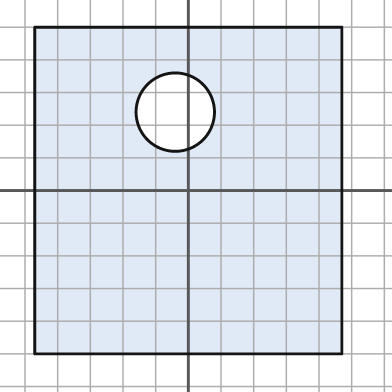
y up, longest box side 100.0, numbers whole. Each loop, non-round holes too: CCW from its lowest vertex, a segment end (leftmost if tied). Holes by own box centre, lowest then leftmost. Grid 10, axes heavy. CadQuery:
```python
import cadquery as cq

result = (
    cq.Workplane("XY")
    .moveTo(-47.0, -50.0)
    .lineTo(47.0, -50.0)
    .lineTo(47.0, 50.0)
    .lineTo(-47.0, 50.0)
    .close()
    .moveTo(-4.0, 24.0)
    .circle(12.0)
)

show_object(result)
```